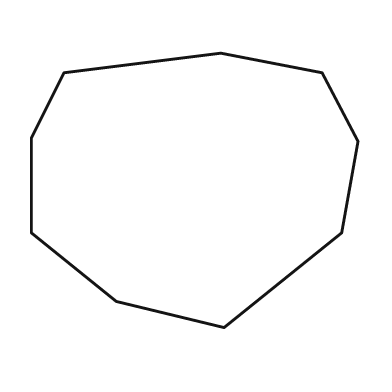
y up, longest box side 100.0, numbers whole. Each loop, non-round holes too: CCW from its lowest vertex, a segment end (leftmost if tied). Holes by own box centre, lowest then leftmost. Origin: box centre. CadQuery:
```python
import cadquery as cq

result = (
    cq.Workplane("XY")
    .moveTo(9.0, -42.0)
    .lineTo(45.0, -13.0)
    .lineTo(50.0, 15.0)
    .lineTo(39.0, 36.0)
    .lineTo(8.0, 42.0)
    .lineTo(-40.0, 36.0)
    .lineTo(-50.0, 16.0)
    .lineTo(-50.0, -13.0)
    .lineTo(-24.0, -34.0)
    .close()
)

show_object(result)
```